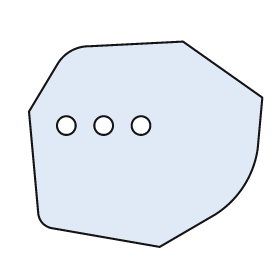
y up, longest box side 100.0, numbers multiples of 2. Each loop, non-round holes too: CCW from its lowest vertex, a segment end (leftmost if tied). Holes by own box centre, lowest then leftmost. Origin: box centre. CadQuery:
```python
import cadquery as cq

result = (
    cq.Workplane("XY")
    .moveTo(6.0, -44.0)
    .lineTo(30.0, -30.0)
    .threePointArc((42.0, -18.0), (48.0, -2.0))
    .lineTo(50.0, 20.0)
    .lineTo(16.0, 44.0)
    .lineTo(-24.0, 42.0)
    .threePointArc((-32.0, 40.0), (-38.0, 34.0))
    .lineTo(-50.0, 14.0)
    .lineTo(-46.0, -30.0)
    .threePointArc((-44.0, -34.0), (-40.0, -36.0))
    .close()
    .moveTo(-34.0, 8.0)
    .circle(4.0)
    .moveTo(-18.0, 8.0)
    .circle(4.0)
    .moveTo(-2.0, 8.0)
    .circle(4.0)
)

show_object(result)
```